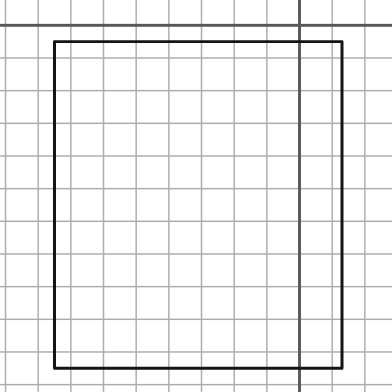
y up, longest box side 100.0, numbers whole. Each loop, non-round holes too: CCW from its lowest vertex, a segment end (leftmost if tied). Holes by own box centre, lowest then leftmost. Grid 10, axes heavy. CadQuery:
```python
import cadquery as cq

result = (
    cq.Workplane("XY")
    .moveTo(-75.0, -105.0)
    .lineTo(13.0, -105.0)
    .lineTo(13.0, -5.0)
    .lineTo(-75.0, -5.0)
    .close()
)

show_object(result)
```